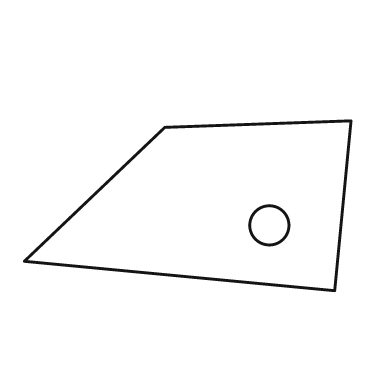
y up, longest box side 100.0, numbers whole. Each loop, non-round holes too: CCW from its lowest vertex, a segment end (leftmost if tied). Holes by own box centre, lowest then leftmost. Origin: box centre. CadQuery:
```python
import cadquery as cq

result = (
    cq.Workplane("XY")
    .moveTo(45.0, -26.0)
    .lineTo(50.0, 26.0)
    .lineTo(-7.0, 24.0)
    .lineTo(-50.0, -17.0)
    .close()
    .moveTo(25.0, -6.0)
    .circle(6.0)
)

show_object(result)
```